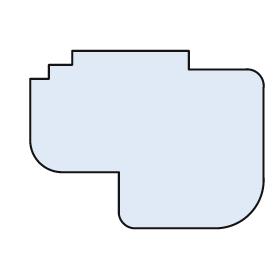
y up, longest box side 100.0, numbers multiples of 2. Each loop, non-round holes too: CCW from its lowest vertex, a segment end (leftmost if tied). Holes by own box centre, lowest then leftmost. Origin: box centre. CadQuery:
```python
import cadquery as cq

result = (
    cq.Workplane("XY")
    .moveTo(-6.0, -38.0)
    .lineTo(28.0, -38.0)
    .threePointArc((44.0, -32.0), (50.0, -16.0))
    .lineTo(50.0, 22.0)
    .threePointArc((48.0, 28.0), (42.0, 30.0))
    .lineTo(18.0, 30.0)
    .lineTo(18.0, 38.0)
    .lineTo(-32.0, 38.0)
    .lineTo(-32.0, 32.0)
    .lineTo(-42.0, 32.0)
    .lineTo(-42.0, 26.0)
    .lineTo(-50.0, 26.0)
    .lineTo(-50.0, 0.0)
    .threePointArc((-46.0, -10.0), (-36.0, -14.0))
    .lineTo(-12.0, -14.0)
    .lineTo(-12.0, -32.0)
    .threePointArc((-10.0, -36.0), (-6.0, -38.0))
    .close()
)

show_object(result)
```